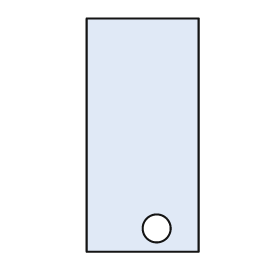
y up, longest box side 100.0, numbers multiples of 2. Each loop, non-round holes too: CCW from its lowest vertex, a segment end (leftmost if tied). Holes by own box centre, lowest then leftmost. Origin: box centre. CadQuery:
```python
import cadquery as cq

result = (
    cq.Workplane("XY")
    .moveTo(-24.0, -50.0)
    .lineTo(24.0, -50.0)
    .lineTo(24.0, 50.0)
    .lineTo(-24.0, 50.0)
    .close()
    .moveTo(6.0, -40.0)
    .circle(6.0)
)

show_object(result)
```